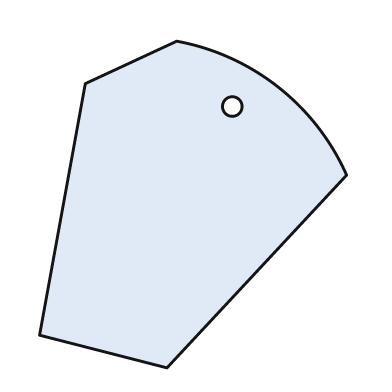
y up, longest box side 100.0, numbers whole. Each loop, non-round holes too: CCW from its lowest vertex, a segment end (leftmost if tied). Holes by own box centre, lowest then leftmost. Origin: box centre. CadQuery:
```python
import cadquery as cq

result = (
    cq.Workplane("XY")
    .moveTo(-8.0, -50.0)
    .lineTo(47.0, 9.0)
    .threePointArc((26.0, 36.0), (-5.0, 50.0))
    .lineTo(-33.0, 37.0)
    .lineTo(-47.0, -40.0)
    .close()
    .moveTo(12.0, 30.0)
    .circle(3.0)
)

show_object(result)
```